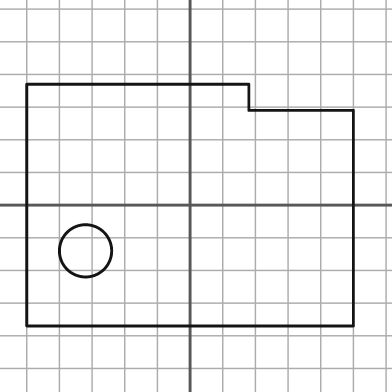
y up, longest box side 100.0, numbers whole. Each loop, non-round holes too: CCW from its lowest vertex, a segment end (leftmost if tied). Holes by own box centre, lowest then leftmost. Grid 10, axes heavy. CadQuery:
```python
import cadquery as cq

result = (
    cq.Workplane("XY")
    .moveTo(-50.0, -37.0)
    .lineTo(50.0, -37.0)
    .lineTo(50.0, 29.0)
    .lineTo(18.0, 29.0)
    .lineTo(18.0, 37.0)
    .lineTo(-50.0, 37.0)
    .close()
    .moveTo(-32.0, -14.0)
    .circle(8.0)
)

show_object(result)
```